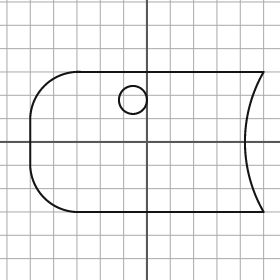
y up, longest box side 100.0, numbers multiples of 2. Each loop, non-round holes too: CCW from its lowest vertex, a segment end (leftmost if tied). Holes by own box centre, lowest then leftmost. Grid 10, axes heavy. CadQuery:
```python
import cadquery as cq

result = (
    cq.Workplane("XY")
    .moveTo(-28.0, -30.0)
    .lineTo(50.0, -30.0)
    .threePointArc((42.0, 0.0), (50.0, 30.0))
    .lineTo(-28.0, 30.0)
    .threePointArc((-44.0, 24.0), (-50.0, 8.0))
    .lineTo(-50.0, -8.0)
    .threePointArc((-44.0, -24.0), (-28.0, -30.0))
    .close()
    .moveTo(-6.0, 18.0)
    .circle(6.0)
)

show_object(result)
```